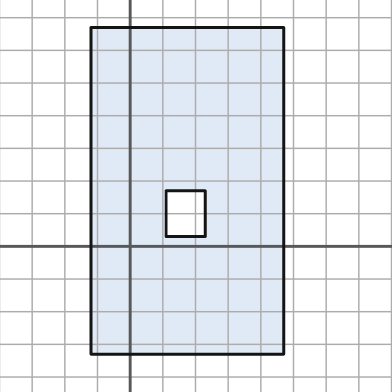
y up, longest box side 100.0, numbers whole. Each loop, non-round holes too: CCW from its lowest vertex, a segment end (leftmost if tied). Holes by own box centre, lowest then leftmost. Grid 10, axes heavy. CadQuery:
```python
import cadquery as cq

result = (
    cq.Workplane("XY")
    .moveTo(-12.0, -33.0)
    .lineTo(47.0, -33.0)
    .lineTo(47.0, 67.0)
    .lineTo(-12.0, 67.0)
    .close()
    .moveTo(11.0, 3.0)
    .lineTo(23.0, 3.0)
    .lineTo(23.0, 17.0)
    .lineTo(11.0, 17.0)
    .close()
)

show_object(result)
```